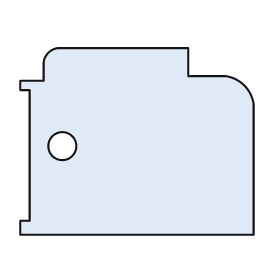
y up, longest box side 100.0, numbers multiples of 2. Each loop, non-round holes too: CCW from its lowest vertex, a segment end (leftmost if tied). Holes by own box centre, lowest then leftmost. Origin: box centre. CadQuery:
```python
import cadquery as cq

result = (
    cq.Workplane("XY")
    .moveTo(-50.0, -40.0)
    .lineTo(50.0, -40.0)
    .lineTo(50.0, 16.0)
    .threePointArc((46.0, 24.0), (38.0, 28.0))
    .lineTo(22.0, 28.0)
    .lineTo(22.0, 40.0)
    .lineTo(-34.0, 40.0)
    .threePointArc((-38.0, 38.0), (-40.0, 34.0))
    .lineTo(-40.0, 26.0)
    .lineTo(-50.0, 26.0)
    .lineTo(-50.0, 22.0)
    .lineTo(-46.0, 22.0)
    .lineTo(-46.0, -34.0)
    .lineTo(-50.0, -34.0)
    .close()
    .moveTo(-32.0, -2.0)
    .circle(6.0)
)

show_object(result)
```